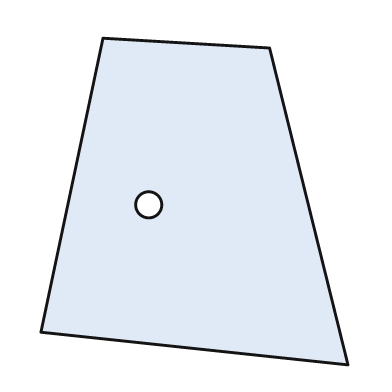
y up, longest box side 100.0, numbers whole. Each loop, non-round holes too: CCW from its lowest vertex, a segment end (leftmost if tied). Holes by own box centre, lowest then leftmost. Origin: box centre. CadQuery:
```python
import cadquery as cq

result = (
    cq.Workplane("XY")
    .moveTo(47.0, -50.0)
    .lineTo(23.0, 47.0)
    .lineTo(-28.0, 50.0)
    .lineTo(-47.0, -40.0)
    .close()
    .moveTo(-14.0, -1.0)
    .circle(4.0)
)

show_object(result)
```